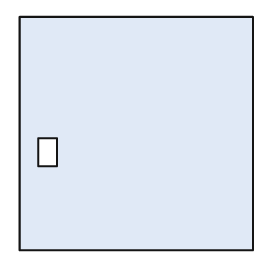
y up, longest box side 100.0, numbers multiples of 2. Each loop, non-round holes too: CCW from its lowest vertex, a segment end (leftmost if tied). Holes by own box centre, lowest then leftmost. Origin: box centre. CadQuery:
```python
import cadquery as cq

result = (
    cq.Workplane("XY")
    .moveTo(-50.0, -50.0)
    .lineTo(50.0, -50.0)
    .lineTo(50.0, 50.0)
    .lineTo(-50.0, 50.0)
    .close()
    .moveTo(-42.0, -14.0)
    .lineTo(-34.0, -14.0)
    .lineTo(-34.0, -2.0)
    .lineTo(-42.0, -2.0)
    .close()
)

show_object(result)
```